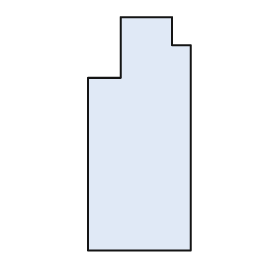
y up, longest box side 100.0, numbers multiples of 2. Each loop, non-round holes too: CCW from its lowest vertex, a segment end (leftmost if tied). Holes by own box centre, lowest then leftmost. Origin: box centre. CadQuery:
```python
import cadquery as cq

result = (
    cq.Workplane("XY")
    .moveTo(-22.0, -50.0)
    .lineTo(22.0, -50.0)
    .lineTo(22.0, 38.0)
    .lineTo(14.0, 38.0)
    .lineTo(14.0, 50.0)
    .lineTo(-8.0, 50.0)
    .lineTo(-8.0, 24.0)
    .lineTo(-22.0, 24.0)
    .close()
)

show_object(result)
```